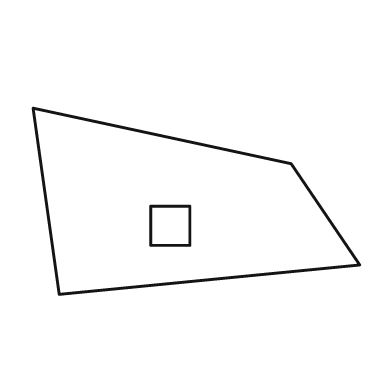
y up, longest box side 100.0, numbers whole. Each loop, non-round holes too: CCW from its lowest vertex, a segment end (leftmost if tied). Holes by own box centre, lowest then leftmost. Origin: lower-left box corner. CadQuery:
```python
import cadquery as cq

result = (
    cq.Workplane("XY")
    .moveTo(8.0, 0.0)
    .lineTo(100.0, 9.0)
    .lineTo(79.0, 40.0)
    .lineTo(0.0, 57.0)
    .close()
    .moveTo(36.0, 15.0)
    .lineTo(48.0, 15.0)
    .lineTo(48.0, 27.0)
    .lineTo(36.0, 27.0)
    .close()
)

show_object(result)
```